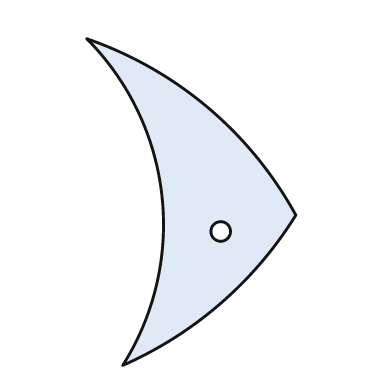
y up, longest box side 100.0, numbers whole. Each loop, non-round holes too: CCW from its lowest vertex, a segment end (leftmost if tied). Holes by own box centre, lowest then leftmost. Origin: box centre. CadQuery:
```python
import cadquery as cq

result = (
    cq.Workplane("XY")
    .moveTo(-21.0, -50.0)
    .threePointArc((9.0, -31.0), (32.0, -4.0))
    .threePointArc((5.0, 29.0), (-32.0, 50.0))
    .threePointArc((-9.0, 2.0), (-21.0, -50.0))
    .close()
    .moveTo(9.0, -9.0)
    .circle(3.0)
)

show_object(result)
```